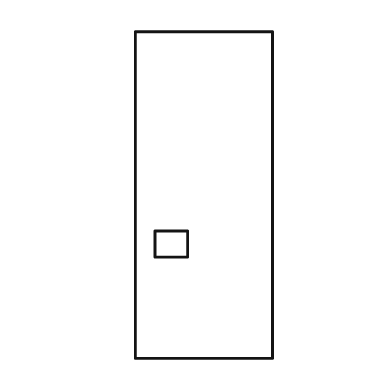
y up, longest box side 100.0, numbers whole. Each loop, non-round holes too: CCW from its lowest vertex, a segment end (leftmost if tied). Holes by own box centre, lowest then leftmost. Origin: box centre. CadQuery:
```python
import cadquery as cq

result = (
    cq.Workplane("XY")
    .moveTo(-21.0, -50.0)
    .lineTo(21.0, -50.0)
    .lineTo(21.0, 50.0)
    .lineTo(-21.0, 50.0)
    .close()
    .moveTo(-15.0, -19.0)
    .lineTo(-5.0, -19.0)
    .lineTo(-5.0, -11.0)
    .lineTo(-15.0, -11.0)
    .close()
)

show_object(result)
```